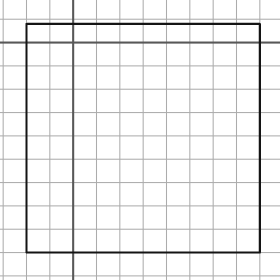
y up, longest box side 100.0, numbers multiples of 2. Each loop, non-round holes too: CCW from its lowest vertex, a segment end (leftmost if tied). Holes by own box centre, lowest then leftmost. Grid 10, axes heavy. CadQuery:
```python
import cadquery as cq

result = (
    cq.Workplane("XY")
    .moveTo(-20.0, -90.0)
    .lineTo(80.0, -90.0)
    .lineTo(80.0, 8.0)
    .lineTo(-20.0, 8.0)
    .close()
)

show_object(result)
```